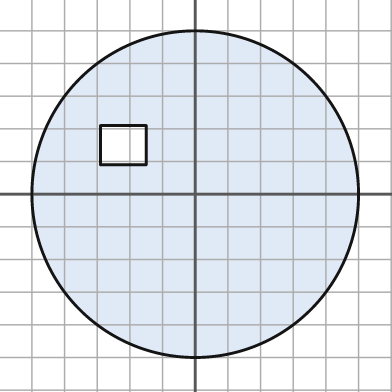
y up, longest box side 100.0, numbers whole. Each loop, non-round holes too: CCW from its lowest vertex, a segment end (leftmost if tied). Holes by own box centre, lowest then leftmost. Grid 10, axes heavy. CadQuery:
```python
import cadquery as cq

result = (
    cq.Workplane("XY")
    .moveTo(0.0, 0.0)
    .circle(50.0)
    .moveTo(-29.0, 9.0)
    .lineTo(-15.0, 9.0)
    .lineTo(-15.0, 21.0)
    .lineTo(-29.0, 21.0)
    .close()
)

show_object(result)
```